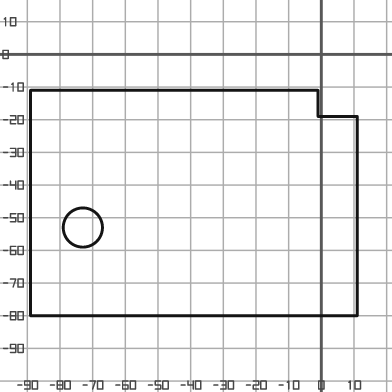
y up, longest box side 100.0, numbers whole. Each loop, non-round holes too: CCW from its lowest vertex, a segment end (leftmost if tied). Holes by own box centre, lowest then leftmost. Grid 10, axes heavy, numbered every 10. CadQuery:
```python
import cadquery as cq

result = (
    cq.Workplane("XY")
    .moveTo(-89.0, -80.0)
    .lineTo(11.0, -80.0)
    .lineTo(11.0, -19.0)
    .lineTo(-1.0, -19.0)
    .lineTo(-1.0, -11.0)
    .lineTo(-89.0, -11.0)
    .close()
    .moveTo(-73.0, -53.0)
    .circle(6.0)
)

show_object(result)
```